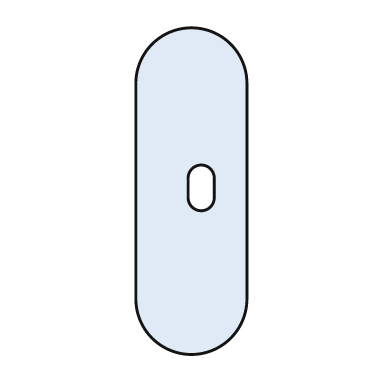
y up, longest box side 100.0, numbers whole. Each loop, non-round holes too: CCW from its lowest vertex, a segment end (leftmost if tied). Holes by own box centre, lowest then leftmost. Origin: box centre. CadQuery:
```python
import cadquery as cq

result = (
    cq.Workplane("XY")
    .moveTo(-17.0, -33.0)
    .threePointArc((0.0, -50.0), (17.0, -33.0))
    .lineTo(17.0, 33.0)
    .threePointArc((0.0, 50.0), (-17.0, 33.0))
    .close()
    .moveTo(-1.0, -2.0)
    .threePointArc((3.0, -6.0), (7.0, -2.0))
    .lineTo(7.0, 4.0)
    .threePointArc((3.0, 8.0), (-1.0, 4.0))
    .close()
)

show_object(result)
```